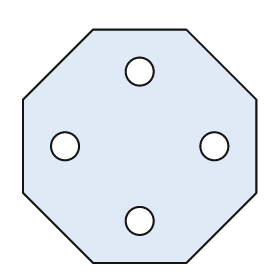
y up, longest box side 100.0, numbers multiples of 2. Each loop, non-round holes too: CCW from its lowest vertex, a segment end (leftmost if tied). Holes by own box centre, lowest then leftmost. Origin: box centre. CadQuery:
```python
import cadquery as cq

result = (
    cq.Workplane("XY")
    .moveTo(-20.0, -50.0)
    .lineTo(20.0, -50.0)
    .lineTo(50.0, -20.0)
    .lineTo(50.0, 20.0)
    .lineTo(20.0, 50.0)
    .lineTo(-20.0, 50.0)
    .lineTo(-50.0, 20.0)
    .lineTo(-50.0, -20.0)
    .close()
    .moveTo(0.0, -32.0)
    .circle(6.0)
    .moveTo(-32.0, 0.0)
    .circle(6.0)
    .moveTo(32.0, 0.0)
    .circle(6.0)
    .moveTo(0.0, 32.0)
    .circle(6.0)
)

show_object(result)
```